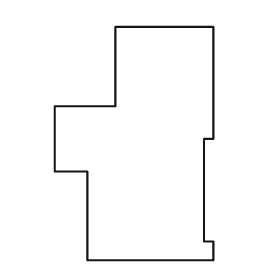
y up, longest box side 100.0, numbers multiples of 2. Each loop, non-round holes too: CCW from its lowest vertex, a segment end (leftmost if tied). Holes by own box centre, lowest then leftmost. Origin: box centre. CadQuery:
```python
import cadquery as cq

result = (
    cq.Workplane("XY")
    .moveTo(-20.0, -50.0)
    .lineTo(34.0, -50.0)
    .lineTo(34.0, -42.0)
    .lineTo(30.0, -42.0)
    .lineTo(30.0, 2.0)
    .lineTo(34.0, 2.0)
    .lineTo(34.0, 50.0)
    .lineTo(-8.0, 50.0)
    .lineTo(-8.0, 16.0)
    .lineTo(-34.0, 16.0)
    .lineTo(-34.0, -12.0)
    .lineTo(-20.0, -12.0)
    .close()
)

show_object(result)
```